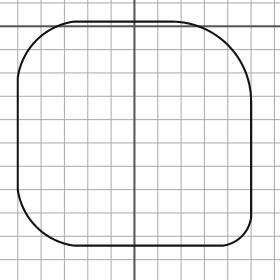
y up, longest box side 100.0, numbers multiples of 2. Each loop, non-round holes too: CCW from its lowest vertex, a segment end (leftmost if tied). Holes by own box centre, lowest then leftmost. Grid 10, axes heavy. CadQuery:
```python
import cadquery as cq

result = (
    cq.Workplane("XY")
    .moveTo(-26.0, -94.0)
    .lineTo(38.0, -94.0)
    .threePointArc((46.0, -90.0), (50.0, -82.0))
    .lineTo(50.0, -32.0)
    .threePointArc((40.0, -8.0), (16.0, 2.0))
    .lineTo(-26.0, 2.0)
    .threePointArc((-42.0, -6.0), (-50.0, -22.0))
    .lineTo(-50.0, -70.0)
    .threePointArc((-42.0, -86.0), (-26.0, -94.0))
    .close()
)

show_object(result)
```